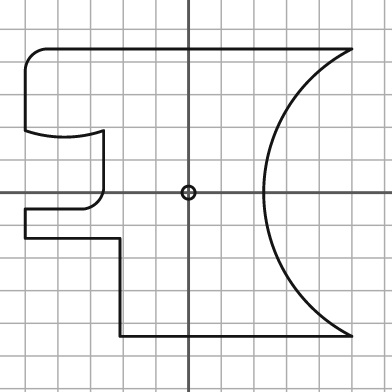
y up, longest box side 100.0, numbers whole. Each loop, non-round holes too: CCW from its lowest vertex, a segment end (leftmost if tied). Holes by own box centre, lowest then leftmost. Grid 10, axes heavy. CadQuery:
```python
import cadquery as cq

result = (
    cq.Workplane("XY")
    .moveTo(-21.0, -44.0)
    .lineTo(50.0, -44.0)
    .threePointArc((23.0, 0.0), (50.0, 44.0))
    .lineTo(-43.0, 44.0)
    .threePointArc((-48.0, 42.0), (-50.0, 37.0))
    .lineTo(-50.0, 19.0)
    .threePointArc((-38.0, 17.0), (-26.0, 19.0))
    .lineTo(-26.0, 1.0)
    .threePointArc((-28.0, -3.0), (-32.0, -5.0))
    .lineTo(-50.0, -5.0)
    .lineTo(-50.0, -14.0)
    .lineTo(-21.0, -14.0)
    .close()
    .moveTo(0.0, 0.0)
    .circle(2.0)
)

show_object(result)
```